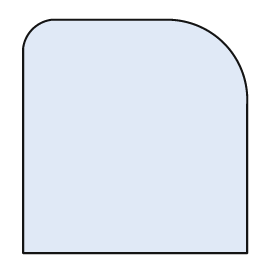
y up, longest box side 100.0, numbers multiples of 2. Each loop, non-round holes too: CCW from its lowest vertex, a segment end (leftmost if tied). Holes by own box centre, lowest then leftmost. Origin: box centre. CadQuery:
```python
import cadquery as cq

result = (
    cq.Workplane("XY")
    .moveTo(-48.0, -50.0)
    .lineTo(48.0, -50.0)
    .lineTo(48.0, 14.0)
    .threePointArc((38.0, 40.0), (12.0, 50.0))
    .lineTo(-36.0, 50.0)
    .threePointArc((-44.0, 46.0), (-48.0, 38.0))
    .close()
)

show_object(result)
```